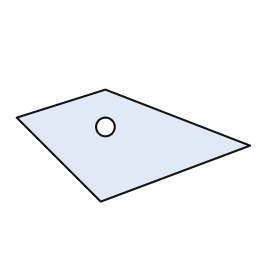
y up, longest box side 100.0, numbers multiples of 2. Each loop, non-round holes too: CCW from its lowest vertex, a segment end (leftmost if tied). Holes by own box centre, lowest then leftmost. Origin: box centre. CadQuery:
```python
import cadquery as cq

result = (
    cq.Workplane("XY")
    .moveTo(-14.0, -24.0)
    .lineTo(50.0, 0.0)
    .lineTo(-12.0, 24.0)
    .lineTo(-50.0, 12.0)
    .close()
    .moveTo(-12.0, 8.0)
    .circle(4.0)
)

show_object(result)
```